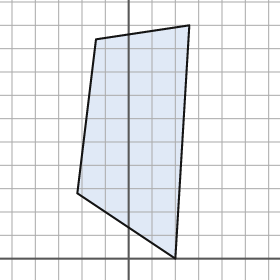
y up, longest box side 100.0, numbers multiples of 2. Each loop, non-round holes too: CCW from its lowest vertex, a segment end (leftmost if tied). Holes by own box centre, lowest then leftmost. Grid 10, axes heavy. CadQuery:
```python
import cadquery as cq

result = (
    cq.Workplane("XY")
    .moveTo(20.0, 0.0)
    .lineTo(26.0, 100.0)
    .lineTo(-14.0, 94.0)
    .lineTo(-22.0, 28.0)
    .close()
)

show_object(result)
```